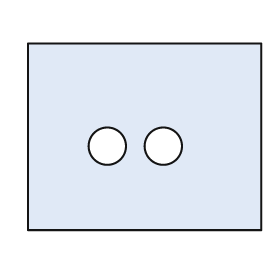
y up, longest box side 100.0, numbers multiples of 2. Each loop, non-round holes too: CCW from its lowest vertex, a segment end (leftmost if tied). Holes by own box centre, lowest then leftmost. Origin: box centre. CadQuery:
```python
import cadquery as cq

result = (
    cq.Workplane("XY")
    .moveTo(-50.0, -40.0)
    .lineTo(50.0, -40.0)
    .lineTo(50.0, 40.0)
    .lineTo(-50.0, 40.0)
    .close()
    .moveTo(-16.0, -4.0)
    .circle(8.0)
    .moveTo(8.0, -4.0)
    .circle(8.0)
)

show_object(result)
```